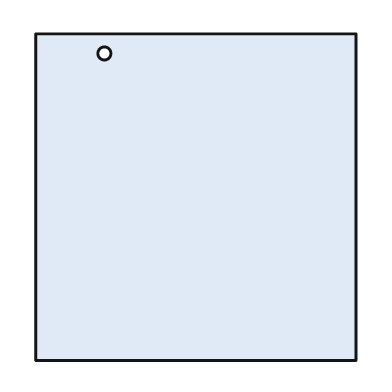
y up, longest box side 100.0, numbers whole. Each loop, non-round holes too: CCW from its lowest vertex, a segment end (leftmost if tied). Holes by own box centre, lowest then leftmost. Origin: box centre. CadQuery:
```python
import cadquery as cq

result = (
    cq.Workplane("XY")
    .moveTo(-49.0, -50.0)
    .lineTo(49.0, -50.0)
    .lineTo(49.0, 50.0)
    .lineTo(-49.0, 50.0)
    .close()
    .moveTo(-28.0, 44.0)
    .circle(2.0)
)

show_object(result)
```